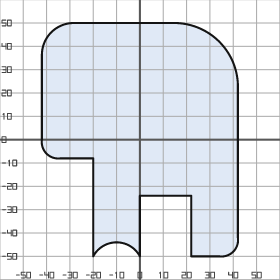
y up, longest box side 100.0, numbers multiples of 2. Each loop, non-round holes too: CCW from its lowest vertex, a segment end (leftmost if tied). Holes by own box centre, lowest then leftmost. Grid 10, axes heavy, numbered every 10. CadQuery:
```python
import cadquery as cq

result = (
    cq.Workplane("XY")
    .moveTo(-20.0, -50.0)
    .threePointArc((-10.0, -44.0), (0.0, -50.0))
    .lineTo(0.0, -24.0)
    .lineTo(22.0, -24.0)
    .lineTo(22.0, -50.0)
    .lineTo(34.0, -50.0)
    .threePointArc((40.0, -48.0), (42.0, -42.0))
    .lineTo(42.0, 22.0)
    .threePointArc((34.0, 42.0), (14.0, 50.0))
    .lineTo(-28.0, 50.0)
    .threePointArc((-38.0, 46.0), (-42.0, 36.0))
    .lineTo(-42.0, 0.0)
    .threePointArc((-40.0, -6.0), (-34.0, -8.0))
    .lineTo(-20.0, -8.0)
    .close()
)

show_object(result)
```